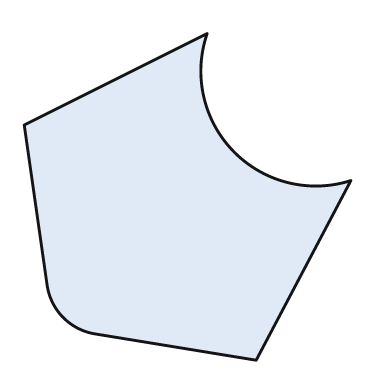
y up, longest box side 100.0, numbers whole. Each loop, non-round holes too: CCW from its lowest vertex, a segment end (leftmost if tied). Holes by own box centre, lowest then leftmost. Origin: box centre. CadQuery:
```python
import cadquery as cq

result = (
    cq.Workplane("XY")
    .moveTo(21.0, -50.0)
    .lineTo(50.0, 5.0)
    .threePointArc((14.0, 14.0), (6.0, 50.0))
    .lineTo(-50.0, 22.0)
    .lineTo(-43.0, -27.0)
    .threePointArc((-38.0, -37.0), (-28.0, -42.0))
    .close()
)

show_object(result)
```